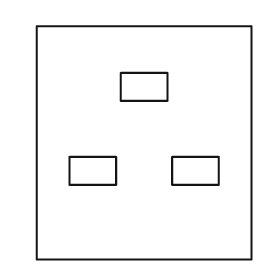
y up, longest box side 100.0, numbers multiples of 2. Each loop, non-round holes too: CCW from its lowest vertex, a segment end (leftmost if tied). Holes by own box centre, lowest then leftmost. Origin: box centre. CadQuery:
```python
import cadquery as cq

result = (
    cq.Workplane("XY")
    .moveTo(-46.0, -50.0)
    .lineTo(46.0, -50.0)
    .lineTo(46.0, 50.0)
    .lineTo(-46.0, 50.0)
    .close()
    .moveTo(-32.0, -18.0)
    .lineTo(-12.0, -18.0)
    .lineTo(-12.0, -6.0)
    .lineTo(-32.0, -6.0)
    .close()
    .moveTo(12.0, -18.0)
    .lineTo(32.0, -18.0)
    .lineTo(32.0, -6.0)
    .lineTo(12.0, -6.0)
    .close()
    .moveTo(-10.0, 18.0)
    .lineTo(10.0, 18.0)
    .lineTo(10.0, 30.0)
    .lineTo(-10.0, 30.0)
    .close()
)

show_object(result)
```